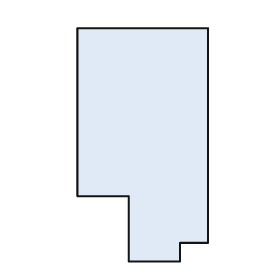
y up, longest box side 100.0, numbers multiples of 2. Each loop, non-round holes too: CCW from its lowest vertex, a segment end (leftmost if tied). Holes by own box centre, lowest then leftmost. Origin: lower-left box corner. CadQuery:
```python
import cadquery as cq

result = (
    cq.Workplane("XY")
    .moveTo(22.0, 0.0)
    .lineTo(44.0, 0.0)
    .lineTo(44.0, 8.0)
    .lineTo(56.0, 8.0)
    .lineTo(56.0, 100.0)
    .lineTo(0.0, 100.0)
    .lineTo(0.0, 28.0)
    .lineTo(22.0, 28.0)
    .close()
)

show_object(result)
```